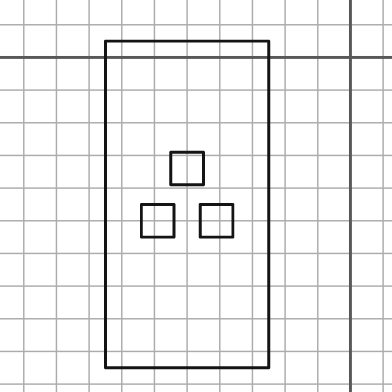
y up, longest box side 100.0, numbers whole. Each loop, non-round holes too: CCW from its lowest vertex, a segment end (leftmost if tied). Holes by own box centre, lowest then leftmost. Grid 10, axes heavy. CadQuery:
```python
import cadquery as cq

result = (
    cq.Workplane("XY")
    .moveTo(-75.0, -95.0)
    .lineTo(-25.0, -95.0)
    .lineTo(-25.0, 5.0)
    .lineTo(-75.0, 5.0)
    .close()
    .moveTo(-64.0, -55.0)
    .lineTo(-54.0, -55.0)
    .lineTo(-54.0, -45.0)
    .lineTo(-64.0, -45.0)
    .close()
    .moveTo(-46.0, -55.0)
    .lineTo(-36.0, -55.0)
    .lineTo(-36.0, -45.0)
    .lineTo(-46.0, -45.0)
    .close()
    .moveTo(-55.0, -39.0)
    .lineTo(-45.0, -39.0)
    .lineTo(-45.0, -29.0)
    .lineTo(-55.0, -29.0)
    .close()
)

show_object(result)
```